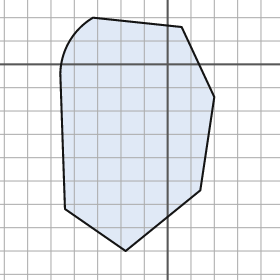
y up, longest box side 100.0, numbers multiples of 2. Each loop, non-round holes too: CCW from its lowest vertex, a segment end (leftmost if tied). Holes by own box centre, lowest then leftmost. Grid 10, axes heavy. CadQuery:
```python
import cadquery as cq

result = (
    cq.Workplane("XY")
    .moveTo(-18.0, -80.0)
    .lineTo(14.0, -54.0)
    .lineTo(20.0, -14.0)
    .lineTo(6.0, 16.0)
    .lineTo(-32.0, 20.0)
    .threePointArc((-42.0, 10.0), (-46.0, -4.0))
    .lineTo(-44.0, -62.0)
    .close()
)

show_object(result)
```